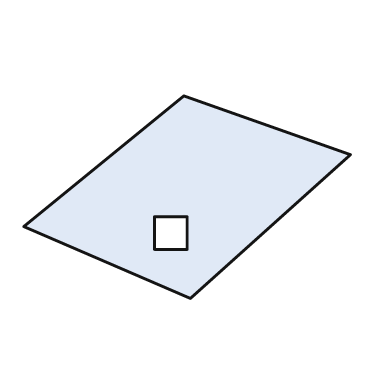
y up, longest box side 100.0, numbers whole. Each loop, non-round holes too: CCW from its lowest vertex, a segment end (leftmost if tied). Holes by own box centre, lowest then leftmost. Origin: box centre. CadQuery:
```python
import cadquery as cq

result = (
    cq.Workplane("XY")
    .moveTo(1.0, -31.0)
    .lineTo(50.0, 13.0)
    .lineTo(-1.0, 31.0)
    .lineTo(-50.0, -9.0)
    .close()
    .moveTo(-10.0, -16.0)
    .lineTo(0.0, -16.0)
    .lineTo(0.0, -6.0)
    .lineTo(-10.0, -6.0)
    .close()
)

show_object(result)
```